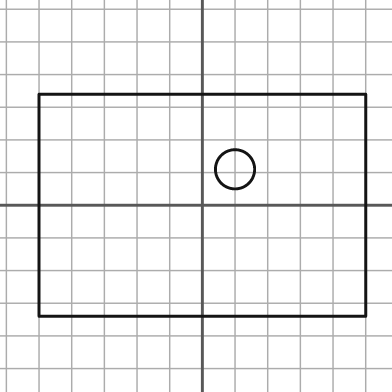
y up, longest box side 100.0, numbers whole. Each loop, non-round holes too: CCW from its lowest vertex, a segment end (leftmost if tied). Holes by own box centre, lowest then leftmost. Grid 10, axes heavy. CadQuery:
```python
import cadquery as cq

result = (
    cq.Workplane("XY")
    .moveTo(-50.0, -34.0)
    .lineTo(50.0, -34.0)
    .lineTo(50.0, 34.0)
    .lineTo(-50.0, 34.0)
    .close()
    .moveTo(10.0, 11.0)
    .circle(6.0)
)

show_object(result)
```